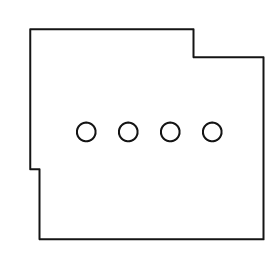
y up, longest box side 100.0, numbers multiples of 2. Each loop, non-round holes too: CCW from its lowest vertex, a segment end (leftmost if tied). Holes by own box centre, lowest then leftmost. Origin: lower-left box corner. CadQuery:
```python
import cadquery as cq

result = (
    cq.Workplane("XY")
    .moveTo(4.0, 0.0)
    .lineTo(100.0, 0.0)
    .lineTo(100.0, 78.0)
    .lineTo(70.0, 78.0)
    .lineTo(70.0, 90.0)
    .lineTo(0.0, 90.0)
    .lineTo(0.0, 30.0)
    .lineTo(4.0, 30.0)
    .close()
    .moveTo(24.0, 46.0)
    .circle(4.0)
    .moveTo(42.0, 46.0)
    .circle(4.0)
    .moveTo(60.0, 46.0)
    .circle(4.0)
    .moveTo(78.0, 46.0)
    .circle(4.0)
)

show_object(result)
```